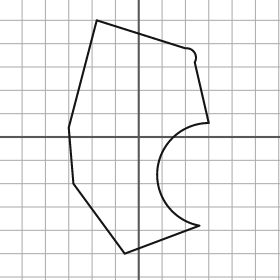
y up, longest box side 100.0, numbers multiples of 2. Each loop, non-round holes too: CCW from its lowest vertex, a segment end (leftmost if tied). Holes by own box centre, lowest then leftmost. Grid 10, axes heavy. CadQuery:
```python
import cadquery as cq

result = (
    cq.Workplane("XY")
    .moveTo(-6.0, -50.0)
    .lineTo(26.0, -38.0)
    .threePointArc((8.0, -14.0), (30.0, 6.0))
    .lineTo(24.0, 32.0)
    .threePointArc((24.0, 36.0), (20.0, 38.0))
    .lineTo(-18.0, 50.0)
    .lineTo(-30.0, 4.0)
    .lineTo(-28.0, -20.0)
    .close()
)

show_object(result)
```